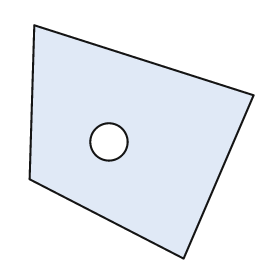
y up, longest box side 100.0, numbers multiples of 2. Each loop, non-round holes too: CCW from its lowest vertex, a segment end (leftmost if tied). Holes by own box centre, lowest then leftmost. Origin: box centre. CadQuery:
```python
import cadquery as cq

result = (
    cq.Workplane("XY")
    .moveTo(18.0, -50.0)
    .lineTo(48.0, 20.0)
    .lineTo(-46.0, 50.0)
    .lineTo(-48.0, -16.0)
    .close()
    .moveTo(-14.0, 0.0)
    .circle(8.0)
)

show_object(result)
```